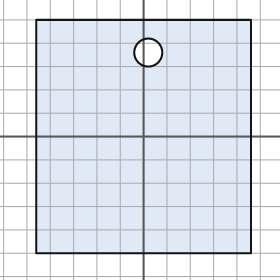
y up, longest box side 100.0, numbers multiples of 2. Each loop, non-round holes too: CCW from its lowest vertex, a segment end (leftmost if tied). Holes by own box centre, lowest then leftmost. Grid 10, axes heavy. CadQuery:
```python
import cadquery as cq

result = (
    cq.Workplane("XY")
    .moveTo(-46.0, -50.0)
    .lineTo(46.0, -50.0)
    .lineTo(46.0, 50.0)
    .lineTo(-46.0, 50.0)
    .close()
    .moveTo(2.0, 36.0)
    .circle(6.0)
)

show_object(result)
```